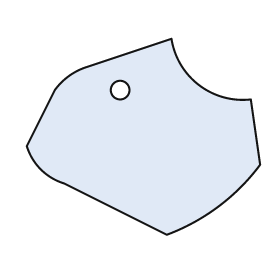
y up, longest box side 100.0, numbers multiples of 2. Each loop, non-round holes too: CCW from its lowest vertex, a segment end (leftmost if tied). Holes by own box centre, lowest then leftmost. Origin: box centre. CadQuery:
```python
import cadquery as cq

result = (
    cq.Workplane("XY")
    .moveTo(10.0, -42.0)
    .threePointArc((32.0, -30.0), (50.0, -12.0))
    .lineTo(46.0, 16.0)
    .threePointArc((24.0, 22.0), (12.0, 42.0))
    .lineTo(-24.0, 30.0)
    .threePointArc((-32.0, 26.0), (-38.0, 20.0))
    .lineTo(-50.0, -4.0)
    .threePointArc((-44.0, -14.0), (-34.0, -20.0))
    .close()
    .moveTo(-10.0, 20.0)
    .circle(4.0)
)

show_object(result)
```